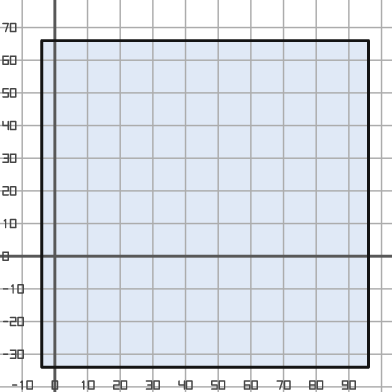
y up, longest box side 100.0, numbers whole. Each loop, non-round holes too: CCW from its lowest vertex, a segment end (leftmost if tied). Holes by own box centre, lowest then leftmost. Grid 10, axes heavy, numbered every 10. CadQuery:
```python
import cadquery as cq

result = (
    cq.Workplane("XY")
    .moveTo(-4.0, -34.0)
    .lineTo(96.0, -34.0)
    .lineTo(96.0, 66.0)
    .lineTo(-4.0, 66.0)
    .close()
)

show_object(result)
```